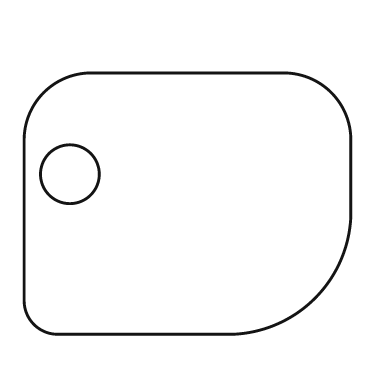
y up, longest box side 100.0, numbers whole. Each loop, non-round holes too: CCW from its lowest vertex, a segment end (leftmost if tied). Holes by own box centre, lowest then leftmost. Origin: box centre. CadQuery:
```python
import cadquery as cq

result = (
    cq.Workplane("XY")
    .moveTo(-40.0, -40.0)
    .lineTo(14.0, -40.0)
    .threePointArc((39.0, -29.0), (50.0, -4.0))
    .lineTo(50.0, 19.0)
    .threePointArc((44.0, 34.0), (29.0, 40.0))
    .lineTo(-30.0, 40.0)
    .threePointArc((-44.0, 34.0), (-50.0, 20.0))
    .lineTo(-50.0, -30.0)
    .threePointArc((-47.0, -37.0), (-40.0, -40.0))
    .close()
    .moveTo(-36.0, 9.0)
    .circle(9.0)
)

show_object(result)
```